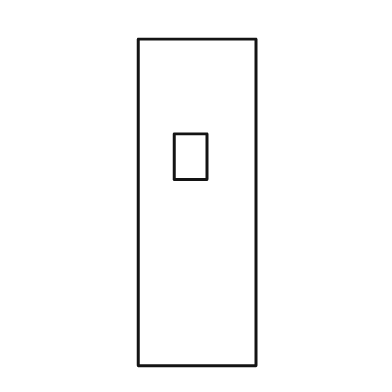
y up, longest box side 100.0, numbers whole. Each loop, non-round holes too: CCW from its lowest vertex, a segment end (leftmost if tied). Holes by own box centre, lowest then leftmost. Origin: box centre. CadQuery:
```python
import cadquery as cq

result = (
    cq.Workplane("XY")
    .moveTo(-18.0, -50.0)
    .lineTo(18.0, -50.0)
    .lineTo(18.0, 50.0)
    .lineTo(-18.0, 50.0)
    .close()
    .moveTo(-7.0, 7.0)
    .lineTo(3.0, 7.0)
    .lineTo(3.0, 21.0)
    .lineTo(-7.0, 21.0)
    .close()
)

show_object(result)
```